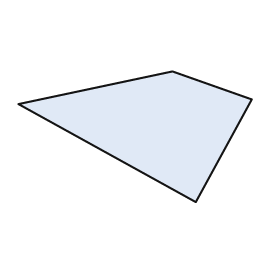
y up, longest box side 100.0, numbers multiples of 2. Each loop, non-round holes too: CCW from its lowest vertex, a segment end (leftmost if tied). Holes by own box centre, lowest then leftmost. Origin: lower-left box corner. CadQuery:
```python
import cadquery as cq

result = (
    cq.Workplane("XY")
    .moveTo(76.0, 0.0)
    .lineTo(100.0, 44.0)
    .lineTo(66.0, 56.0)
    .lineTo(0.0, 42.0)
    .close()
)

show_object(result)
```